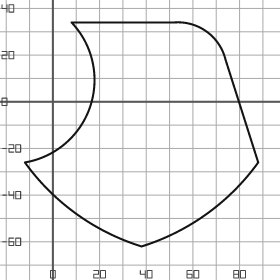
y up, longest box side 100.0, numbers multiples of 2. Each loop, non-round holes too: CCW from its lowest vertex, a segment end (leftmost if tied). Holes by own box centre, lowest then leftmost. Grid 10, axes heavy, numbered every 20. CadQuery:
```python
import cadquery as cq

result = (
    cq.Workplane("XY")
    .moveTo(38.0, -62.0)
    .threePointArc((66.0, -48.0), (88.0, -26.0))
    .lineTo(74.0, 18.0)
    .threePointArc((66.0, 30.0), (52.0, 34.0))
    .lineTo(8.0, 34.0)
    .threePointArc((16.0, -2.0), (-12.0, -26.0))
    .threePointArc((10.0, -48.0), (38.0, -62.0))
    .close()
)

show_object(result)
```